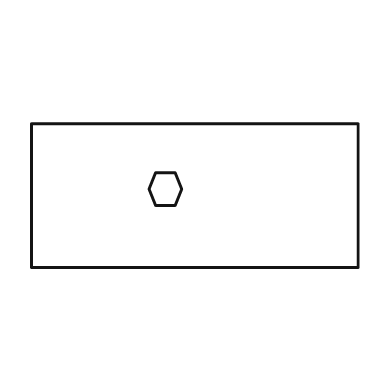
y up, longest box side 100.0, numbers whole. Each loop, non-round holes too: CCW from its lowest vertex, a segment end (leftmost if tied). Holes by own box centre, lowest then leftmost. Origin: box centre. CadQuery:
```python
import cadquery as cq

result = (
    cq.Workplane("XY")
    .moveTo(-50.0, -22.0)
    .lineTo(50.0, -22.0)
    .lineTo(50.0, 22.0)
    .lineTo(-50.0, 22.0)
    .close()
    .moveTo(-12.0, -3.0)
    .lineTo(-6.0, -3.0)
    .lineTo(-4.0, 2.0)
    .lineTo(-6.0, 7.0)
    .lineTo(-12.0, 7.0)
    .lineTo(-14.0, 2.0)
    .close()
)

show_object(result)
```